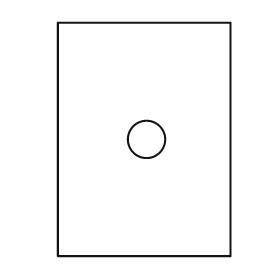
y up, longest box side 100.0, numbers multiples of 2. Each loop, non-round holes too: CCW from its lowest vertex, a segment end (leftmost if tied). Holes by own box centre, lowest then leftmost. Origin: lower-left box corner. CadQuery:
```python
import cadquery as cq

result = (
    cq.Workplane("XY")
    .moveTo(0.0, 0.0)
    .lineTo(74.0, 0.0)
    .lineTo(74.0, 100.0)
    .lineTo(0.0, 100.0)
    .close()
    .moveTo(38.0, 50.0)
    .circle(8.0)
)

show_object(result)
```